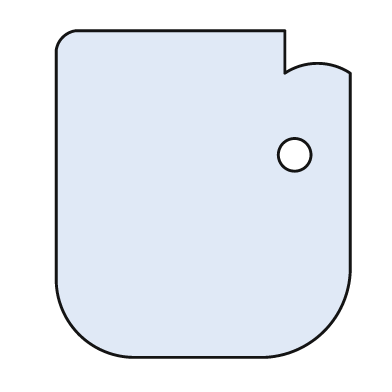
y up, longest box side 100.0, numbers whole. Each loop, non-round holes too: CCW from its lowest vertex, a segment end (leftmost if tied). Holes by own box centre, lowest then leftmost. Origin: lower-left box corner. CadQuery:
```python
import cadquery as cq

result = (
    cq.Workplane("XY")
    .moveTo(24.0, 0.0)
    .lineTo(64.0, 0.0)
    .threePointArc((82.0, 8.0), (90.0, 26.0))
    .lineTo(90.0, 87.0)
    .threePointArc((80.0, 90.0), (70.0, 87.0))
    .lineTo(70.0, 100.0)
    .lineTo(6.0, 100.0)
    .threePointArc((2.0, 98.0), (0.0, 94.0))
    .lineTo(0.0, 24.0)
    .threePointArc((7.0, 7.0), (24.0, 0.0))
    .close()
    .moveTo(73.0, 62.0)
    .circle(5.0)
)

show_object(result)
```